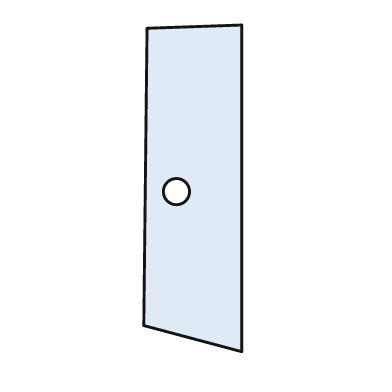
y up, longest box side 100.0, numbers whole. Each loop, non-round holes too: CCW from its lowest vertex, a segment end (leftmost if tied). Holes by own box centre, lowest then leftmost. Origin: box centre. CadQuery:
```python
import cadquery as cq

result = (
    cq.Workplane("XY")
    .moveTo(15.0, -50.0)
    .lineTo(15.0, 50.0)
    .lineTo(-14.0, 49.0)
    .lineTo(-15.0, -42.0)
    .close()
    .moveTo(-5.0, -1.0)
    .circle(4.0)
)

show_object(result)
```